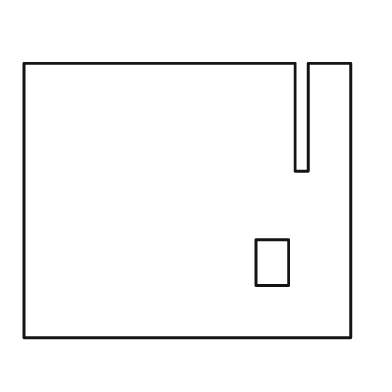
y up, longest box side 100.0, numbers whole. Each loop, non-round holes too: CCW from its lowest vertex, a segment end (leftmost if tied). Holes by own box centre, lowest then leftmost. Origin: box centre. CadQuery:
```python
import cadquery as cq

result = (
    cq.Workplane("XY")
    .moveTo(-50.0, -42.0)
    .lineTo(50.0, -42.0)
    .lineTo(50.0, 42.0)
    .lineTo(37.0, 42.0)
    .lineTo(37.0, 9.0)
    .lineTo(33.0, 9.0)
    .lineTo(33.0, 42.0)
    .lineTo(-50.0, 42.0)
    .close()
    .moveTo(21.0, -26.0)
    .lineTo(31.0, -26.0)
    .lineTo(31.0, -12.0)
    .lineTo(21.0, -12.0)
    .close()
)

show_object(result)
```